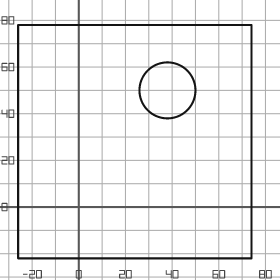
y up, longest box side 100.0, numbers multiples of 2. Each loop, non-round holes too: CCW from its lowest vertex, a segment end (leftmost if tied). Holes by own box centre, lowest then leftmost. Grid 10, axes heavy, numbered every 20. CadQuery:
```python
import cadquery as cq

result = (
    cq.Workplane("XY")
    .moveTo(-26.0, -22.0)
    .lineTo(74.0, -22.0)
    .lineTo(74.0, 78.0)
    .lineTo(-26.0, 78.0)
    .close()
    .moveTo(38.0, 50.0)
    .circle(12.0)
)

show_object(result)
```